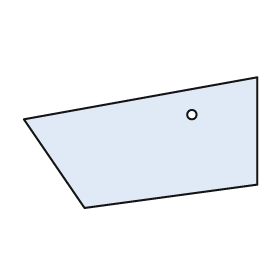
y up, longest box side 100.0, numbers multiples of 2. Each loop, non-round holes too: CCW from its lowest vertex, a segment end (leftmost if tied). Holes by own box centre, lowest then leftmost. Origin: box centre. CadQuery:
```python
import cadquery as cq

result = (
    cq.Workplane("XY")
    .moveTo(-24.0, -28.0)
    .lineTo(50.0, -18.0)
    .lineTo(50.0, 28.0)
    .lineTo(-50.0, 10.0)
    .close()
    .moveTo(22.0, 12.0)
    .circle(2.0)
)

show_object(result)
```